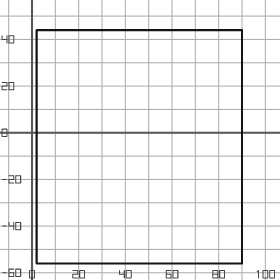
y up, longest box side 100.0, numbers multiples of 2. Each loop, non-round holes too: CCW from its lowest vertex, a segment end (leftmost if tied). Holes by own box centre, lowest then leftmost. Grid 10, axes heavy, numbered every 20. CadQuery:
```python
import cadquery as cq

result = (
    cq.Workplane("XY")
    .moveTo(2.0, -56.0)
    .lineTo(90.0, -56.0)
    .lineTo(90.0, 44.0)
    .lineTo(2.0, 44.0)
    .close()
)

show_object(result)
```